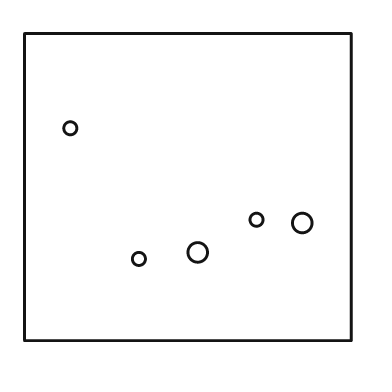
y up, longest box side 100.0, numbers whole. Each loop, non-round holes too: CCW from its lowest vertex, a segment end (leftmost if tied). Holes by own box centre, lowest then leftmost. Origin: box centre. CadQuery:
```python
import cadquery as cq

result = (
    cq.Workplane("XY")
    .moveTo(-50.0, -47.0)
    .lineTo(50.0, -47.0)
    .lineTo(50.0, 47.0)
    .lineTo(-50.0, 47.0)
    .close()
    .moveTo(-15.0, -22.0)
    .circle(2.0)
    .moveTo(3.0, -20.0)
    .circle(3.0)
    .moveTo(35.0, -11.0)
    .circle(3.0)
    .moveTo(21.0, -10.0)
    .circle(2.0)
    .moveTo(-36.0, 18.0)
    .circle(2.0)
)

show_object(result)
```